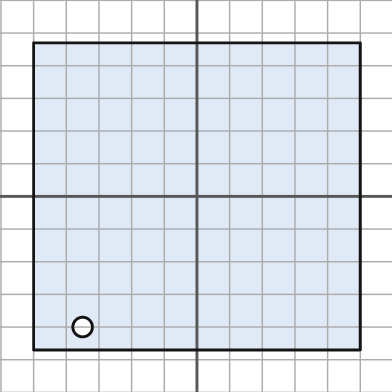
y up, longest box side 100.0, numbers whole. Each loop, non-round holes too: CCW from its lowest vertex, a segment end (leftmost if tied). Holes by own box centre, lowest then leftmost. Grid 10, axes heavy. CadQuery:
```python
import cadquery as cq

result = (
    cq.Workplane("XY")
    .moveTo(-50.0, -47.0)
    .lineTo(50.0, -47.0)
    .lineTo(50.0, 47.0)
    .lineTo(-50.0, 47.0)
    .close()
    .moveTo(-35.0, -40.0)
    .circle(3.0)
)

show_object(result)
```